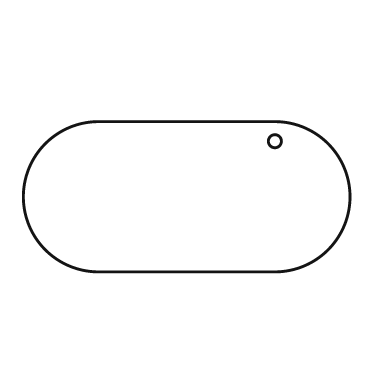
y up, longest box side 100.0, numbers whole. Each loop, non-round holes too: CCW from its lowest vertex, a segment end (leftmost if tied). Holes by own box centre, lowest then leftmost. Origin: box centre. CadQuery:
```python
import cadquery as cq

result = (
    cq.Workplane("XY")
    .moveTo(-27.0, -23.0)
    .lineTo(27.0, -23.0)
    .threePointArc((50.0, 0.0), (27.0, 23.0))
    .lineTo(-27.0, 23.0)
    .threePointArc((-50.0, 0.0), (-27.0, -23.0))
    .close()
    .moveTo(27.0, 17.0)
    .circle(2.0)
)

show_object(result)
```